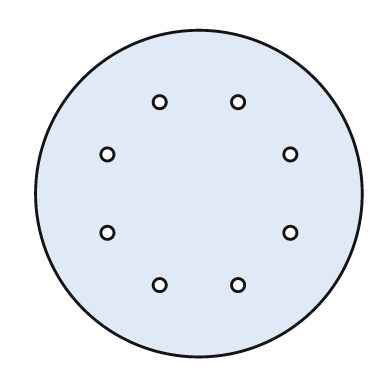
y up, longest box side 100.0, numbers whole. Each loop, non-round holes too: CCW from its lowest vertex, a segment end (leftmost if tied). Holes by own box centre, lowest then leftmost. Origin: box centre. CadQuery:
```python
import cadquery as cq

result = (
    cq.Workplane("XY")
    .moveTo(0.0, 0.0)
    .circle(50.0)
    .moveTo(-12.0, -28.0)
    .circle(2.0)
    .moveTo(12.0, -28.0)
    .circle(2.0)
    .moveTo(-28.0, -12.0)
    .circle(2.0)
    .moveTo(28.0, -12.0)
    .circle(2.0)
    .moveTo(-28.0, 12.0)
    .circle(2.0)
    .moveTo(28.0, 12.0)
    .circle(2.0)
    .moveTo(-12.0, 28.0)
    .circle(2.0)
    .moveTo(12.0, 28.0)
    .circle(2.0)
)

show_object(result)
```